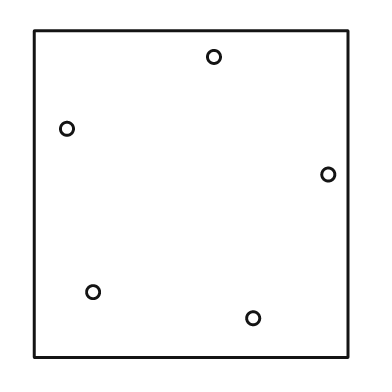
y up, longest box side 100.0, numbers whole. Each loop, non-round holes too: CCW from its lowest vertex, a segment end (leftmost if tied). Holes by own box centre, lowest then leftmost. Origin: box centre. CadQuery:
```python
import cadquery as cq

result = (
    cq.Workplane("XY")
    .moveTo(-48.0, -50.0)
    .lineTo(48.0, -50.0)
    .lineTo(48.0, 50.0)
    .lineTo(-48.0, 50.0)
    .close()
    .moveTo(19.0, -38.0)
    .circle(2.0)
    .moveTo(-30.0, -30.0)
    .circle(2.0)
    .moveTo(42.0, 6.0)
    .circle(2.0)
    .moveTo(-38.0, 20.0)
    .circle(2.0)
    .moveTo(7.0, 42.0)
    .circle(2.0)
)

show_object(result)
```